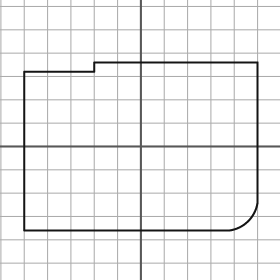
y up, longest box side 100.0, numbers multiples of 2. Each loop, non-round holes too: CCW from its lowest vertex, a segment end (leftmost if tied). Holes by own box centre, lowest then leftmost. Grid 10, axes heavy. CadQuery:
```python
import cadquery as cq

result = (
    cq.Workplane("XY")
    .moveTo(-50.0, -36.0)
    .lineTo(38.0, -36.0)
    .threePointArc((46.0, -32.0), (50.0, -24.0))
    .lineTo(50.0, 36.0)
    .lineTo(-20.0, 36.0)
    .lineTo(-20.0, 32.0)
    .lineTo(-50.0, 32.0)
    .close()
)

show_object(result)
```